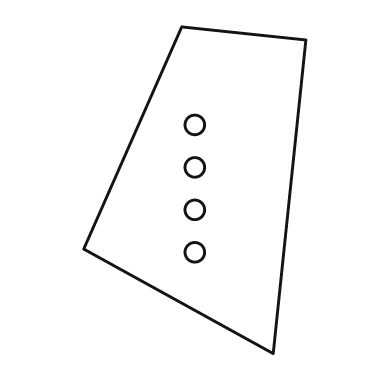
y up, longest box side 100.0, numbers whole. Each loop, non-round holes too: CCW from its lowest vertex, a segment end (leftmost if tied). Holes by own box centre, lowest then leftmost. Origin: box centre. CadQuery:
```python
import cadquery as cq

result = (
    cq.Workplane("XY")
    .moveTo(24.0, -50.0)
    .lineTo(34.0, 46.0)
    .lineTo(-4.0, 50.0)
    .lineTo(-34.0, -18.0)
    .close()
    .moveTo(0.0, -19.0)
    .circle(3.0)
    .moveTo(0.0, -6.0)
    .circle(3.0)
    .moveTo(0.0, 7.0)
    .circle(3.0)
    .moveTo(0.0, 20.0)
    .circle(3.0)
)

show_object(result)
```